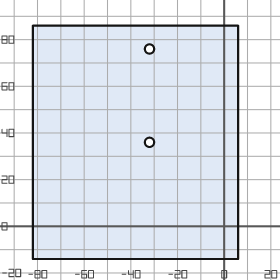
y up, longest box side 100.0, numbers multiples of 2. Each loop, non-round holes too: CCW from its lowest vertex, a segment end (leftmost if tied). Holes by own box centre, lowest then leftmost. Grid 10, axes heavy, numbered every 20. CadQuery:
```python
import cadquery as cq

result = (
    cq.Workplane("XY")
    .moveTo(-82.0, -14.0)
    .lineTo(6.0, -14.0)
    .lineTo(6.0, 86.0)
    .lineTo(-82.0, 86.0)
    .close()
    .moveTo(-32.0, 36.0)
    .circle(2.0)
    .moveTo(-32.0, 76.0)
    .circle(2.0)
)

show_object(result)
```